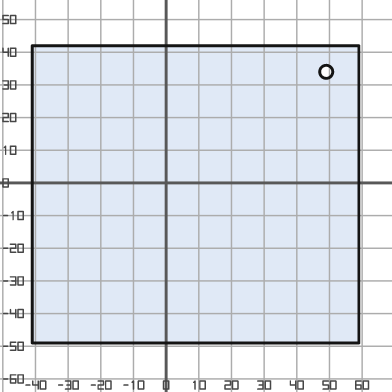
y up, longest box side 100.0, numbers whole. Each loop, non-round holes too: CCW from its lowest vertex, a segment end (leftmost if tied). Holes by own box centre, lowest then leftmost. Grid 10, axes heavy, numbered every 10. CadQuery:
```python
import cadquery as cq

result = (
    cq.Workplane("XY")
    .moveTo(-41.0, -49.0)
    .lineTo(59.0, -49.0)
    .lineTo(59.0, 42.0)
    .lineTo(-41.0, 42.0)
    .close()
    .moveTo(49.0, 34.0)
    .circle(2.0)
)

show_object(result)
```